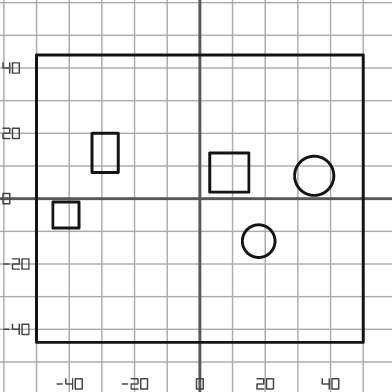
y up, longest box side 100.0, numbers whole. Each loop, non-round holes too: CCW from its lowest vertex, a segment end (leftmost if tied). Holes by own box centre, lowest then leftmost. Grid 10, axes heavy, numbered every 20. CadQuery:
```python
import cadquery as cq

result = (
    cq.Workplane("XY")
    .moveTo(-50.0, -44.0)
    .lineTo(50.0, -44.0)
    .lineTo(50.0, 44.0)
    .lineTo(-50.0, 44.0)
    .close()
    .moveTo(18.0, -13.0)
    .circle(5.0)
    .moveTo(-45.0, -9.0)
    .lineTo(-37.0, -9.0)
    .lineTo(-37.0, -1.0)
    .lineTo(-45.0, -1.0)
    .close()
    .moveTo(35.0, 7.0)
    .circle(6.0)
    .moveTo(3.0, 2.0)
    .lineTo(15.0, 2.0)
    .lineTo(15.0, 14.0)
    .lineTo(3.0, 14.0)
    .close()
    .moveTo(-33.0, 8.0)
    .lineTo(-25.0, 8.0)
    .lineTo(-25.0, 20.0)
    .lineTo(-33.0, 20.0)
    .close()
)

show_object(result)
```